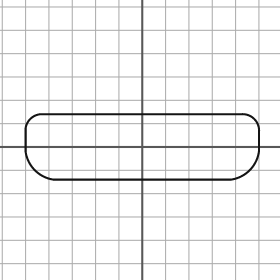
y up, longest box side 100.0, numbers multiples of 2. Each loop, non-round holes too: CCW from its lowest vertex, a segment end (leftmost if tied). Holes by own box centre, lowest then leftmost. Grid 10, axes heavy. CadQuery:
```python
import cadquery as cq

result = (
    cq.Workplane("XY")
    .moveTo(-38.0, -14.0)
    .lineTo(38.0, -14.0)
    .threePointArc((46.0, -10.0), (50.0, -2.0))
    .lineTo(50.0, 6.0)
    .threePointArc((48.0, 12.0), (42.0, 14.0))
    .lineTo(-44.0, 14.0)
    .threePointArc((-48.0, 12.0), (-50.0, 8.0))
    .lineTo(-50.0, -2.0)
    .threePointArc((-46.0, -10.0), (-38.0, -14.0))
    .close()
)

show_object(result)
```